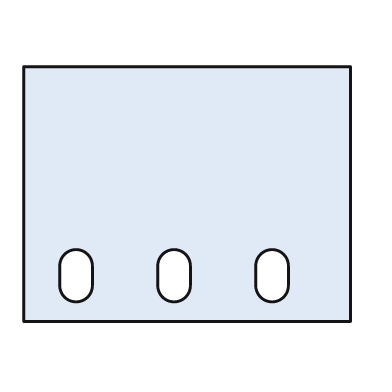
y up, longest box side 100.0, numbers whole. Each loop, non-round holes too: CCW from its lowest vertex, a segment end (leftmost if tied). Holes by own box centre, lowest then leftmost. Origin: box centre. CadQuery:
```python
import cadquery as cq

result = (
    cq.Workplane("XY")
    .moveTo(-50.0, -39.0)
    .lineTo(50.0, -39.0)
    .lineTo(50.0, 39.0)
    .lineTo(-50.0, 39.0)
    .close()
    .moveTo(-39.0, -28.0)
    .threePointArc((-34.0, -33.0), (-29.0, -28.0))
    .lineTo(-29.0, -22.0)
    .threePointArc((-34.0, -17.0), (-39.0, -22.0))
    .close()
    .moveTo(-9.0, -28.0)
    .threePointArc((-4.0, -33.0), (1.0, -28.0))
    .lineTo(1.0, -22.0)
    .threePointArc((-4.0, -17.0), (-9.0, -22.0))
    .close()
    .moveTo(21.0, -28.0)
    .threePointArc((26.0, -33.0), (31.0, -28.0))
    .lineTo(31.0, -22.0)
    .threePointArc((26.0, -17.0), (21.0, -22.0))
    .close()
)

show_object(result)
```